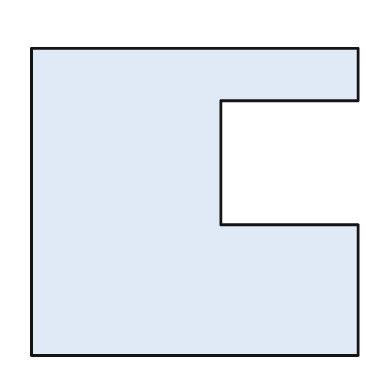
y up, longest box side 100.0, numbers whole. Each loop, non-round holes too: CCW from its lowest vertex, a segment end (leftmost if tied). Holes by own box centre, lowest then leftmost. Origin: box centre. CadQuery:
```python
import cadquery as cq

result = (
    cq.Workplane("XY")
    .moveTo(-50.0, -47.0)
    .lineTo(50.0, -47.0)
    .lineTo(50.0, -7.0)
    .lineTo(8.0, -7.0)
    .lineTo(8.0, 31.0)
    .lineTo(50.0, 31.0)
    .lineTo(50.0, 47.0)
    .lineTo(-50.0, 47.0)
    .close()
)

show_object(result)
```